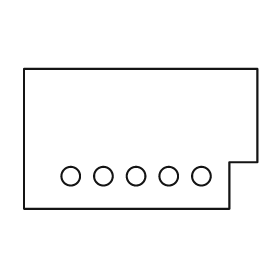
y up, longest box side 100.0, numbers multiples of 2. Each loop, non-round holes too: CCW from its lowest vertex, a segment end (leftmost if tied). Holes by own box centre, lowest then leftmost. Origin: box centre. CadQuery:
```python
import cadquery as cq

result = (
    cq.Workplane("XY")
    .moveTo(-50.0, -30.0)
    .lineTo(38.0, -30.0)
    .lineTo(38.0, -10.0)
    .lineTo(50.0, -10.0)
    .lineTo(50.0, 30.0)
    .lineTo(-50.0, 30.0)
    .close()
    .moveTo(-30.0, -16.0)
    .circle(4.0)
    .moveTo(-16.0, -16.0)
    .circle(4.0)
    .moveTo(-2.0, -16.0)
    .circle(4.0)
    .moveTo(12.0, -16.0)
    .circle(4.0)
    .moveTo(26.0, -16.0)
    .circle(4.0)
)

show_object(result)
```